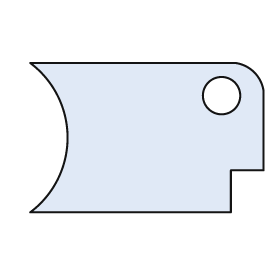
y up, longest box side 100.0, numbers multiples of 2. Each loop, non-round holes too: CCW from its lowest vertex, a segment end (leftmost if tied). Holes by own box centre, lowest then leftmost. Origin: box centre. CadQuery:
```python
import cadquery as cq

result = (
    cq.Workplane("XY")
    .moveTo(-50.0, -32.0)
    .lineTo(36.0, -32.0)
    .lineTo(36.0, -14.0)
    .lineTo(50.0, -14.0)
    .lineTo(50.0, 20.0)
    .threePointArc((46.0, 28.0), (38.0, 32.0))
    .lineTo(-50.0, 32.0)
    .threePointArc((-34.0, 0.0), (-50.0, -32.0))
    .close()
    .moveTo(32.0, 18.0)
    .circle(8.0)
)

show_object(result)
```